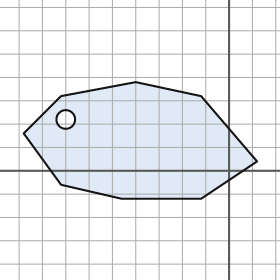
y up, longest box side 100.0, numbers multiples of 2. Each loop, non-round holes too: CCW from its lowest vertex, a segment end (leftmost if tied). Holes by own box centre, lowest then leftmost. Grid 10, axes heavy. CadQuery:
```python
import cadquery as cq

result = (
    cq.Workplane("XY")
    .moveTo(-46.0, -12.0)
    .lineTo(-12.0, -12.0)
    .lineTo(12.0, 4.0)
    .lineTo(-12.0, 32.0)
    .lineTo(-40.0, 38.0)
    .lineTo(-72.0, 32.0)
    .lineTo(-88.0, 16.0)
    .lineTo(-72.0, -6.0)
    .close()
    .moveTo(-70.0, 22.0)
    .circle(4.0)
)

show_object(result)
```